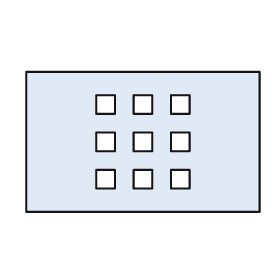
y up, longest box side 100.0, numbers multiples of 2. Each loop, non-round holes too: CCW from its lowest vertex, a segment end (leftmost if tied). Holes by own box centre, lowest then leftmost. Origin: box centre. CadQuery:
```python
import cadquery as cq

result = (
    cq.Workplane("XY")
    .moveTo(-50.0, -30.0)
    .lineTo(50.0, -30.0)
    .lineTo(50.0, 30.0)
    .lineTo(-50.0, 30.0)
    .close()
    .moveTo(-20.0, -20.0)
    .lineTo(-12.0, -20.0)
    .lineTo(-12.0, -12.0)
    .lineTo(-20.0, -12.0)
    .close()
    .moveTo(-4.0, -20.0)
    .lineTo(4.0, -20.0)
    .lineTo(4.0, -12.0)
    .lineTo(-4.0, -12.0)
    .close()
    .moveTo(12.0, -20.0)
    .lineTo(20.0, -20.0)
    .lineTo(20.0, -12.0)
    .lineTo(12.0, -12.0)
    .close()
    .moveTo(-20.0, -4.0)
    .lineTo(-12.0, -4.0)
    .lineTo(-12.0, 4.0)
    .lineTo(-20.0, 4.0)
    .close()
    .moveTo(-4.0, -4.0)
    .lineTo(4.0, -4.0)
    .lineTo(4.0, 4.0)
    .lineTo(-4.0, 4.0)
    .close()
    .moveTo(12.0, -4.0)
    .lineTo(20.0, -4.0)
    .lineTo(20.0, 4.0)
    .lineTo(12.0, 4.0)
    .close()
    .moveTo(-20.0, 12.0)
    .lineTo(-12.0, 12.0)
    .lineTo(-12.0, 20.0)
    .lineTo(-20.0, 20.0)
    .close()
    .moveTo(-4.0, 12.0)
    .lineTo(4.0, 12.0)
    .lineTo(4.0, 20.0)
    .lineTo(-4.0, 20.0)
    .close()
    .moveTo(12.0, 12.0)
    .lineTo(20.0, 12.0)
    .lineTo(20.0, 20.0)
    .lineTo(12.0, 20.0)
    .close()
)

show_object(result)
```